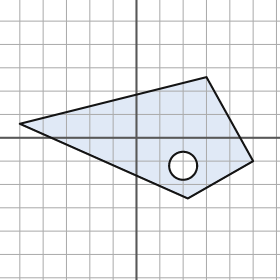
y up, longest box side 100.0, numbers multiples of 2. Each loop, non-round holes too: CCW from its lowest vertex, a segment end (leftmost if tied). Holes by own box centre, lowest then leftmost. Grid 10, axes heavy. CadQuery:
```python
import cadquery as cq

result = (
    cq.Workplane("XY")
    .moveTo(22.0, -26.0)
    .lineTo(50.0, -10.0)
    .lineTo(30.0, 26.0)
    .lineTo(-50.0, 6.0)
    .close()
    .moveTo(20.0, -12.0)
    .circle(6.0)
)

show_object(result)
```